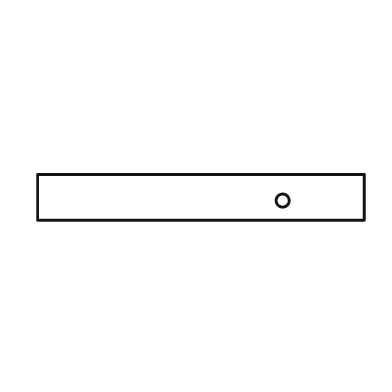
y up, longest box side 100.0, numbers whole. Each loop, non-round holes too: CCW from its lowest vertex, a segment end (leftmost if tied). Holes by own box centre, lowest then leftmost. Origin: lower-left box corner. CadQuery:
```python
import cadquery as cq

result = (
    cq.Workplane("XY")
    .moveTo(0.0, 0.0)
    .lineTo(100.0, 0.0)
    .lineTo(100.0, 14.0)
    .lineTo(0.0, 14.0)
    .close()
    .moveTo(75.0, 6.0)
    .circle(2.0)
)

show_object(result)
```